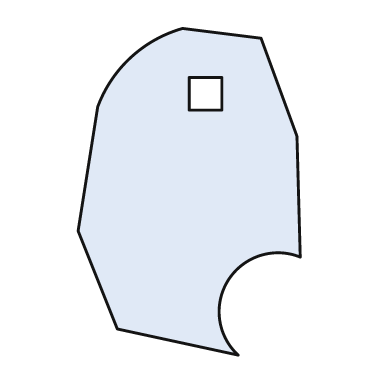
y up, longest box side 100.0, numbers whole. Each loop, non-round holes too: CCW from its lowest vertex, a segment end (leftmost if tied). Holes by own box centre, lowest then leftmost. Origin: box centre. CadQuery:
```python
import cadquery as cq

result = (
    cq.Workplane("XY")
    .moveTo(15.0, -50.0)
    .threePointArc((12.0, -27.0), (34.0, -20.0))
    .lineTo(33.0, 17.0)
    .lineTo(22.0, 47.0)
    .lineTo(-2.0, 50.0)
    .threePointArc((-18.0, 41.0), (-28.0, 26.0))
    .lineTo(-34.0, -12.0)
    .lineTo(-22.0, -42.0)
    .close()
    .moveTo(0.0, 25.0)
    .lineTo(10.0, 25.0)
    .lineTo(10.0, 35.0)
    .lineTo(0.0, 35.0)
    .close()
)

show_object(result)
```